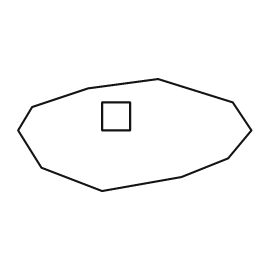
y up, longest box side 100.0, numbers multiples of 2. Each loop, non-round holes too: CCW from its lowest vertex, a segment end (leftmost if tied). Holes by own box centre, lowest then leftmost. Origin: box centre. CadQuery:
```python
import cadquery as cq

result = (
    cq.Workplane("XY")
    .moveTo(-14.0, -24.0)
    .lineTo(20.0, -18.0)
    .lineTo(40.0, -10.0)
    .lineTo(50.0, 2.0)
    .lineTo(42.0, 14.0)
    .lineTo(10.0, 24.0)
    .lineTo(-20.0, 20.0)
    .lineTo(-44.0, 12.0)
    .lineTo(-50.0, 2.0)
    .lineTo(-40.0, -14.0)
    .close()
    .moveTo(-14.0, 2.0)
    .lineTo(-2.0, 2.0)
    .lineTo(-2.0, 14.0)
    .lineTo(-14.0, 14.0)
    .close()
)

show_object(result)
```